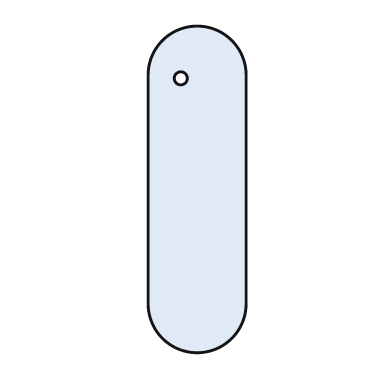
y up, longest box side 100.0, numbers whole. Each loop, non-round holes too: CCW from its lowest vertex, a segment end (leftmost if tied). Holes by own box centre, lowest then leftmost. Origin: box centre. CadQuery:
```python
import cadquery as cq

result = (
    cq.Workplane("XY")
    .moveTo(-15.0, -35.0)
    .threePointArc((0.0, -50.0), (15.0, -35.0))
    .lineTo(15.0, 35.0)
    .threePointArc((0.0, 50.0), (-15.0, 35.0))
    .close()
    .moveTo(-5.0, 34.0)
    .circle(2.0)
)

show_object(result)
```